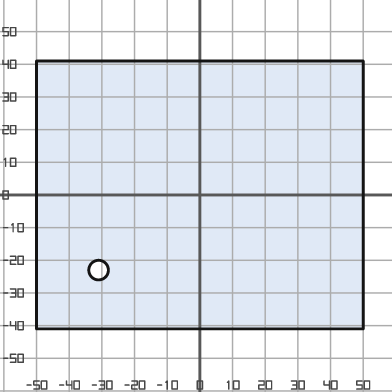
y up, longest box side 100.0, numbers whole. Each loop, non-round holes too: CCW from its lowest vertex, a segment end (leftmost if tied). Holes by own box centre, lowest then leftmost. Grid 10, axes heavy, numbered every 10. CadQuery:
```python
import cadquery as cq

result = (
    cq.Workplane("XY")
    .moveTo(-50.0, -41.0)
    .lineTo(50.0, -41.0)
    .lineTo(50.0, 41.0)
    .lineTo(-50.0, 41.0)
    .close()
    .moveTo(-31.0, -23.0)
    .circle(3.0)
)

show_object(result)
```